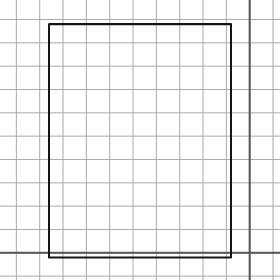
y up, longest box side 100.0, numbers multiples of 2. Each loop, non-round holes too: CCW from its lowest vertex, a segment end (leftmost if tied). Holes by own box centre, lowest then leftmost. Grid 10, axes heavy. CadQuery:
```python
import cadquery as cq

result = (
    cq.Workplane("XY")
    .moveTo(-86.0, -2.0)
    .lineTo(-8.0, -2.0)
    .lineTo(-8.0, 98.0)
    .lineTo(-86.0, 98.0)
    .close()
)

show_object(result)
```